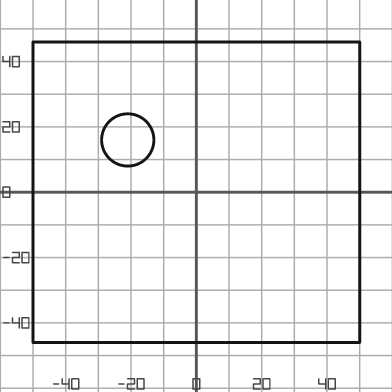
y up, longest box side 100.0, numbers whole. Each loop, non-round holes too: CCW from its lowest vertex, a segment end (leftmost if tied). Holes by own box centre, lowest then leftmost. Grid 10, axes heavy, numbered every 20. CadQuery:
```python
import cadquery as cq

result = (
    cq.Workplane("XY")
    .moveTo(-50.0, -46.0)
    .lineTo(50.0, -46.0)
    .lineTo(50.0, 46.0)
    .lineTo(-50.0, 46.0)
    .close()
    .moveTo(-21.0, 16.0)
    .circle(8.0)
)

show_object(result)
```